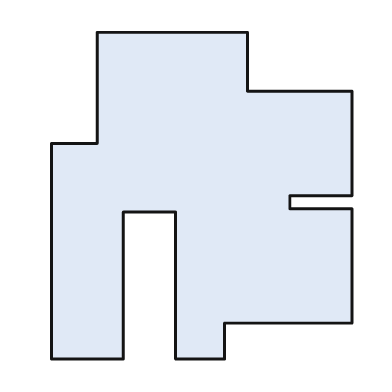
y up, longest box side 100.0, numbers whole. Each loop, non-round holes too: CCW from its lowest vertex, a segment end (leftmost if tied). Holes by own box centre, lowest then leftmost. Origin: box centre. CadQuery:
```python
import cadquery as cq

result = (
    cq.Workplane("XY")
    .moveTo(-46.0, -50.0)
    .lineTo(-24.0, -50.0)
    .lineTo(-24.0, -5.0)
    .lineTo(-8.0, -5.0)
    .lineTo(-8.0, -50.0)
    .lineTo(7.0, -50.0)
    .lineTo(7.0, -39.0)
    .lineTo(46.0, -39.0)
    .lineTo(46.0, -4.0)
    .lineTo(27.0, -4.0)
    .lineTo(27.0, 0.0)
    .lineTo(46.0, 0.0)
    .lineTo(46.0, 32.0)
    .lineTo(14.0, 32.0)
    .lineTo(14.0, 50.0)
    .lineTo(-32.0, 50.0)
    .lineTo(-32.0, 16.0)
    .lineTo(-46.0, 16.0)
    .close()
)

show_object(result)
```